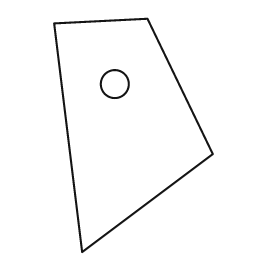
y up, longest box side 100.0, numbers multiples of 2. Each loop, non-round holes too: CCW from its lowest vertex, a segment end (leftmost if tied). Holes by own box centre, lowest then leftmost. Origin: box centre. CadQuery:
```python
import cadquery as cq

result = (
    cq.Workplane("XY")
    .moveTo(-22.0, -50.0)
    .lineTo(34.0, -8.0)
    .lineTo(6.0, 50.0)
    .lineTo(-34.0, 48.0)
    .close()
    .moveTo(-8.0, 22.0)
    .circle(6.0)
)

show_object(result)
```